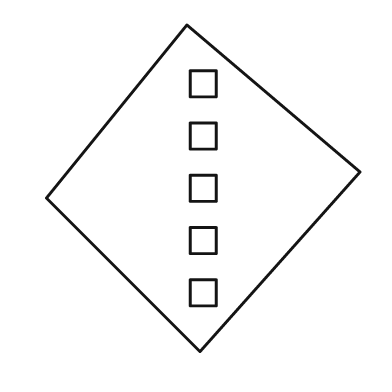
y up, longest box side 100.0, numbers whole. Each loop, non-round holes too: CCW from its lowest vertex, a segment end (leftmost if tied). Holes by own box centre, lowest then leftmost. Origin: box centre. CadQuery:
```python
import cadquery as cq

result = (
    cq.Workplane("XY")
    .moveTo(-1.0, -50.0)
    .lineTo(48.0, 5.0)
    .lineTo(-5.0, 50.0)
    .lineTo(-48.0, -3.0)
    .close()
    .moveTo(-4.0, -36.0)
    .lineTo(4.0, -36.0)
    .lineTo(4.0, -28.0)
    .lineTo(-4.0, -28.0)
    .close()
    .moveTo(-4.0, -20.0)
    .lineTo(4.0, -20.0)
    .lineTo(4.0, -12.0)
    .lineTo(-4.0, -12.0)
    .close()
    .moveTo(-4.0, -4.0)
    .lineTo(4.0, -4.0)
    .lineTo(4.0, 4.0)
    .lineTo(-4.0, 4.0)
    .close()
    .moveTo(-4.0, 12.0)
    .lineTo(4.0, 12.0)
    .lineTo(4.0, 20.0)
    .lineTo(-4.0, 20.0)
    .close()
    .moveTo(-4.0, 28.0)
    .lineTo(4.0, 28.0)
    .lineTo(4.0, 36.0)
    .lineTo(-4.0, 36.0)
    .close()
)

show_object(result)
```